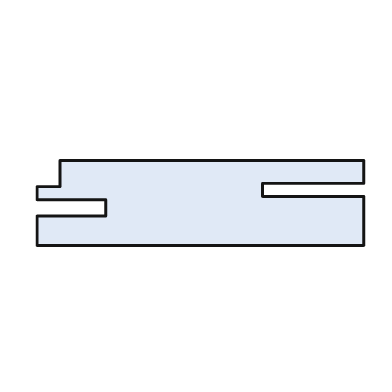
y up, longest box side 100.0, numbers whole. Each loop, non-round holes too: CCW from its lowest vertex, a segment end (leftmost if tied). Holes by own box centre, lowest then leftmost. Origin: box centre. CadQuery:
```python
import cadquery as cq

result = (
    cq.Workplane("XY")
    .moveTo(-50.0, -13.0)
    .lineTo(50.0, -13.0)
    .lineTo(50.0, 2.0)
    .lineTo(19.0, 2.0)
    .lineTo(19.0, 6.0)
    .lineTo(50.0, 6.0)
    .lineTo(50.0, 13.0)
    .lineTo(-43.0, 13.0)
    .lineTo(-43.0, 5.0)
    .lineTo(-50.0, 5.0)
    .lineTo(-50.0, 1.0)
    .lineTo(-29.0, 1.0)
    .lineTo(-29.0, -4.0)
    .lineTo(-50.0, -4.0)
    .close()
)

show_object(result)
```